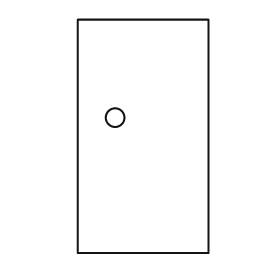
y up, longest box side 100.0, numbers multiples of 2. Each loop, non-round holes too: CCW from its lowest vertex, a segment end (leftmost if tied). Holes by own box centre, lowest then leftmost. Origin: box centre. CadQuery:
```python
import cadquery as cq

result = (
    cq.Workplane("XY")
    .moveTo(-28.0, -50.0)
    .lineTo(28.0, -50.0)
    .lineTo(28.0, 50.0)
    .lineTo(-28.0, 50.0)
    .close()
    .moveTo(-12.0, 8.0)
    .circle(4.0)
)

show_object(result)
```